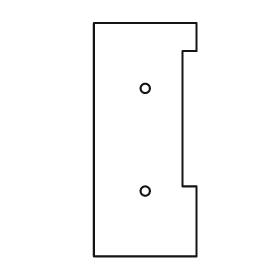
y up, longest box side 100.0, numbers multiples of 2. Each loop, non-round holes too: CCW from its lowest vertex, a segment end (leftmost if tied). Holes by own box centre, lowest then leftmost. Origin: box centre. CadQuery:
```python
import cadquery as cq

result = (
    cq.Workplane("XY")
    .moveTo(-22.0, -50.0)
    .lineTo(22.0, -50.0)
    .lineTo(22.0, -20.0)
    .lineTo(16.0, -20.0)
    .lineTo(16.0, 38.0)
    .lineTo(22.0, 38.0)
    .lineTo(22.0, 50.0)
    .lineTo(-22.0, 50.0)
    .close()
    .moveTo(0.0, -22.0)
    .circle(2.0)
    .moveTo(0.0, 22.0)
    .circle(2.0)
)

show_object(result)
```